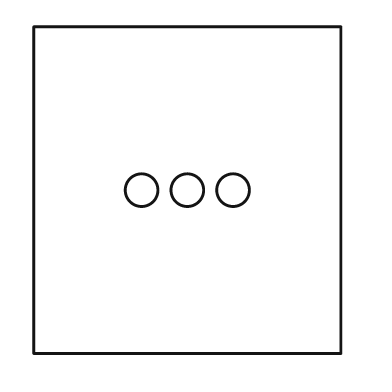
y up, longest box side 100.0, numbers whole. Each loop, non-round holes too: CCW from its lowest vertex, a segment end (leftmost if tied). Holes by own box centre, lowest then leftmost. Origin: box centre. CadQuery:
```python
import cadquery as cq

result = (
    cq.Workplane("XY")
    .moveTo(-47.0, -50.0)
    .lineTo(47.0, -50.0)
    .lineTo(47.0, 50.0)
    .lineTo(-47.0, 50.0)
    .close()
    .moveTo(-14.0, 0.0)
    .circle(5.0)
    .moveTo(0.0, 0.0)
    .circle(5.0)
    .moveTo(14.0, 0.0)
    .circle(5.0)
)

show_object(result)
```